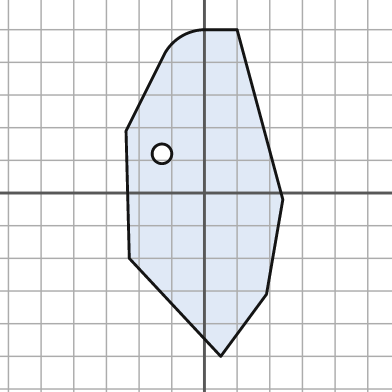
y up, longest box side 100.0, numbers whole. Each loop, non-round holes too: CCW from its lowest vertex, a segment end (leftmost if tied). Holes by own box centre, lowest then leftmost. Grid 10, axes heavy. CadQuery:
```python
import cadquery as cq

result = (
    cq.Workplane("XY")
    .moveTo(5.0, -50.0)
    .lineTo(19.0, -31.0)
    .lineTo(24.0, -2.0)
    .lineTo(10.0, 50.0)
    .lineTo(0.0, 50.0)
    .threePointArc((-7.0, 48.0), (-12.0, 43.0))
    .lineTo(-24.0, 19.0)
    .lineTo(-23.0, -20.0)
    .close()
    .moveTo(-13.0, 12.0)
    .circle(3.0)
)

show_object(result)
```